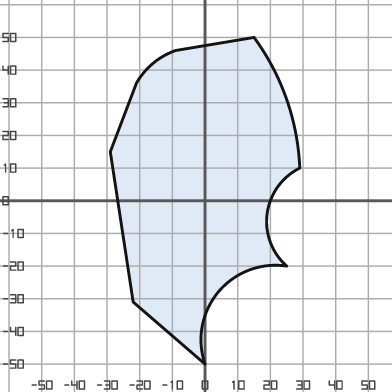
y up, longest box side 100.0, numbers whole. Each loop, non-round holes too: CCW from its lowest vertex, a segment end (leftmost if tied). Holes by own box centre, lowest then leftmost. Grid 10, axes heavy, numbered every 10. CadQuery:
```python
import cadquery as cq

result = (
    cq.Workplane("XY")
    .moveTo(0.0, -50.0)
    .threePointArc((4.0, -28.0), (25.0, -20.0))
    .threePointArc((19.0, -4.0), (29.0, 10.0))
    .threePointArc((25.0, 31.0), (15.0, 50.0))
    .lineTo(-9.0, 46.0)
    .threePointArc((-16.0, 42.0), (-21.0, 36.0))
    .lineTo(-29.0, 15.0)
    .lineTo(-22.0, -31.0)
    .close()
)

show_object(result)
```